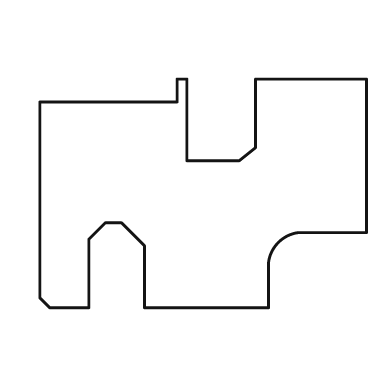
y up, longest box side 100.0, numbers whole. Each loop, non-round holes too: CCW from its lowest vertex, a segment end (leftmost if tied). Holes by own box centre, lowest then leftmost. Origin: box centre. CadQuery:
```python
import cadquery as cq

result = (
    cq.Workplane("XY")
    .moveTo(-47.0, -35.0)
    .lineTo(-35.0, -35.0)
    .lineTo(-35.0, -14.0)
    .lineTo(-30.0, -9.0)
    .lineTo(-25.0, -9.0)
    .lineTo(-18.0, -16.0)
    .lineTo(-18.0, -35.0)
    .lineTo(20.0, -35.0)
    .lineTo(20.0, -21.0)
    .threePointArc((23.0, -15.0), (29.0, -12.0))
    .lineTo(50.0, -12.0)
    .lineTo(50.0, 35.0)
    .lineTo(16.0, 35.0)
    .lineTo(16.0, 14.0)
    .lineTo(11.0, 10.0)
    .lineTo(-5.0, 10.0)
    .lineTo(-5.0, 35.0)
    .lineTo(-8.0, 35.0)
    .lineTo(-8.0, 28.0)
    .lineTo(-50.0, 28.0)
    .lineTo(-50.0, -32.0)
    .close()
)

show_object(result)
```